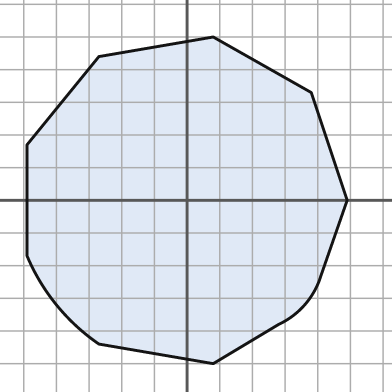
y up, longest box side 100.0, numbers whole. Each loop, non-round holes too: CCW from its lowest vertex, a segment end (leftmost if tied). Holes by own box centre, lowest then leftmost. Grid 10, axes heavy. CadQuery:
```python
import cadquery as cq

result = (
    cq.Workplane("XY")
    .moveTo(8.0, -50.0)
    .lineTo(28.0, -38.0)
    .threePointArc((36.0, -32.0), (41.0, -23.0))
    .lineTo(49.0, 0.0)
    .lineTo(38.0, 33.0)
    .lineTo(8.0, 50.0)
    .lineTo(-27.0, 44.0)
    .lineTo(-49.0, 17.0)
    .lineTo(-49.0, -17.0)
    .threePointArc((-40.0, -32.0), (-27.0, -44.0))
    .close()
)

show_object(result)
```